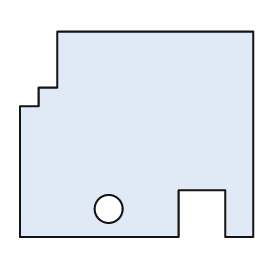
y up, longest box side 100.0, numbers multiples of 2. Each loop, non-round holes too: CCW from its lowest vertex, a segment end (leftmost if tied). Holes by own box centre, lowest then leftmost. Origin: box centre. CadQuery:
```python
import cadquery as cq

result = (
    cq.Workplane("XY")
    .moveTo(-50.0, -44.0)
    .lineTo(18.0, -44.0)
    .lineTo(18.0, -24.0)
    .lineTo(38.0, -24.0)
    .lineTo(38.0, -44.0)
    .lineTo(50.0, -44.0)
    .lineTo(50.0, 44.0)
    .lineTo(-34.0, 44.0)
    .lineTo(-34.0, 20.0)
    .lineTo(-42.0, 20.0)
    .lineTo(-42.0, 12.0)
    .lineTo(-50.0, 12.0)
    .close()
    .moveTo(-12.0, -32.0)
    .circle(6.0)
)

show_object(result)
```